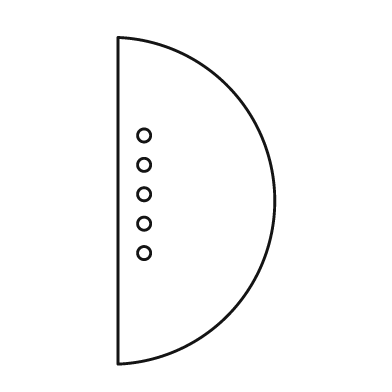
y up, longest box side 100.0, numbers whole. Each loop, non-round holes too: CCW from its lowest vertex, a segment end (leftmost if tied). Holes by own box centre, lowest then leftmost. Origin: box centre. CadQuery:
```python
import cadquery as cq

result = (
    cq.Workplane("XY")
    .moveTo(-24.0, -50.0)
    .threePointArc((24.0, 0.0), (-24.0, 50.0))
    .close()
    .moveTo(-16.0, -16.0)
    .circle(2.0)
    .moveTo(-16.0, -7.0)
    .circle(2.0)
    .moveTo(-16.0, 2.0)
    .circle(2.0)
    .moveTo(-16.0, 11.0)
    .circle(2.0)
    .moveTo(-16.0, 20.0)
    .circle(2.0)
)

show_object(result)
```